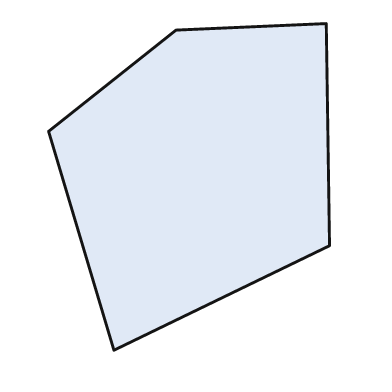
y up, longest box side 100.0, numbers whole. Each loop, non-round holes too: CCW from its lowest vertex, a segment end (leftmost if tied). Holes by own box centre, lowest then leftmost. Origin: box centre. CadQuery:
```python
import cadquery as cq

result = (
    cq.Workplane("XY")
    .moveTo(-23.0, -50.0)
    .lineTo(43.0, -18.0)
    .lineTo(42.0, 50.0)
    .lineTo(-4.0, 48.0)
    .lineTo(-43.0, 17.0)
    .close()
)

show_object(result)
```